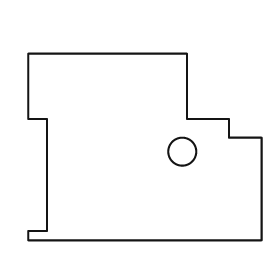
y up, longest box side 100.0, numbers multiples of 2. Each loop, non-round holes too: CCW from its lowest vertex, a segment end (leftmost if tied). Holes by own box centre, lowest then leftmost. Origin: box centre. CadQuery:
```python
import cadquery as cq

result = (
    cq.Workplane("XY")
    .moveTo(-50.0, -40.0)
    .lineTo(50.0, -40.0)
    .lineTo(50.0, 4.0)
    .lineTo(36.0, 4.0)
    .lineTo(36.0, 12.0)
    .lineTo(18.0, 12.0)
    .lineTo(18.0, 40.0)
    .lineTo(-50.0, 40.0)
    .lineTo(-50.0, 12.0)
    .lineTo(-42.0, 12.0)
    .lineTo(-42.0, -36.0)
    .lineTo(-50.0, -36.0)
    .close()
    .moveTo(16.0, -2.0)
    .circle(6.0)
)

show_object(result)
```